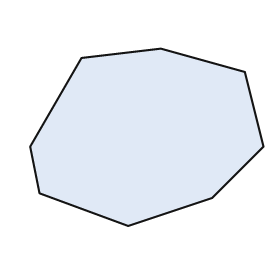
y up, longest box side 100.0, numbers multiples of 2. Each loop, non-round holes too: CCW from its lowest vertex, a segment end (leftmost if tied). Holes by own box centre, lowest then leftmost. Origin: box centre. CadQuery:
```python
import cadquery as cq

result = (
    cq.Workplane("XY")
    .moveTo(-8.0, -38.0)
    .lineTo(28.0, -26.0)
    .lineTo(50.0, -4.0)
    .lineTo(42.0, 28.0)
    .lineTo(6.0, 38.0)
    .lineTo(-28.0, 34.0)
    .lineTo(-50.0, -4.0)
    .lineTo(-46.0, -24.0)
    .close()
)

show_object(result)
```